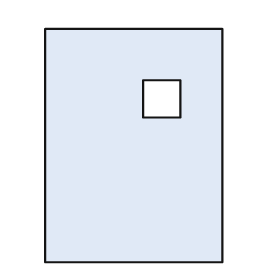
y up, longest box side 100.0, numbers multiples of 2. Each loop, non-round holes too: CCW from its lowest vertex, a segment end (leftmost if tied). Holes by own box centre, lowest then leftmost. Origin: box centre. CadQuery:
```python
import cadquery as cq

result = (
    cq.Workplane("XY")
    .moveTo(-38.0, -50.0)
    .lineTo(38.0, -50.0)
    .lineTo(38.0, 50.0)
    .lineTo(-38.0, 50.0)
    .close()
    .moveTo(4.0, 12.0)
    .lineTo(20.0, 12.0)
    .lineTo(20.0, 28.0)
    .lineTo(4.0, 28.0)
    .close()
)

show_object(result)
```